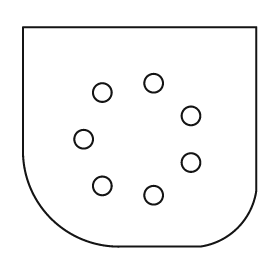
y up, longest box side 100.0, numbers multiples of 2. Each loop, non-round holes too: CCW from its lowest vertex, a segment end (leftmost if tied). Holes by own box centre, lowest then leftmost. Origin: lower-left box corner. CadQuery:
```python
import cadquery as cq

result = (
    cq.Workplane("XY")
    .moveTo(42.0, 0.0)
    .lineTo(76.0, 0.0)
    .threePointArc((92.0, 8.0), (100.0, 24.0))
    .lineTo(100.0, 94.0)
    .lineTo(0.0, 94.0)
    .lineTo(0.0, 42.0)
    .threePointArc((12.0, 12.0), (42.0, 0.0))
    .close()
    .moveTo(56.0, 22.0)
    .circle(4.0)
    .moveTo(34.0, 26.0)
    .circle(4.0)
    .moveTo(72.0, 36.0)
    .circle(4.0)
    .moveTo(26.0, 46.0)
    .circle(4.0)
    .moveTo(72.0, 56.0)
    .circle(4.0)
    .moveTo(34.0, 66.0)
    .circle(4.0)
    .moveTo(56.0, 70.0)
    .circle(4.0)
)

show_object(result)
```